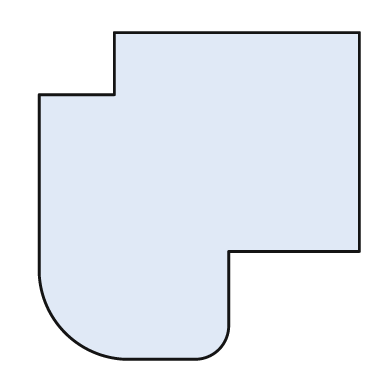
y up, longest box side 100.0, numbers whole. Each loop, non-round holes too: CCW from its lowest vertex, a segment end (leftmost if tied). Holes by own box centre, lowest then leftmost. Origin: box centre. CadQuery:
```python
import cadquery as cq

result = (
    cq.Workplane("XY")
    .moveTo(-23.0, -50.0)
    .lineTo(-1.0, -50.0)
    .threePointArc((6.0, -47.0), (9.0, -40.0))
    .lineTo(9.0, -17.0)
    .lineTo(49.0, -17.0)
    .lineTo(49.0, 50.0)
    .lineTo(-26.0, 50.0)
    .lineTo(-26.0, 31.0)
    .lineTo(-49.0, 31.0)
    .lineTo(-49.0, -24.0)
    .threePointArc((-41.0, -42.0), (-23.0, -50.0))
    .close()
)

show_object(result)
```